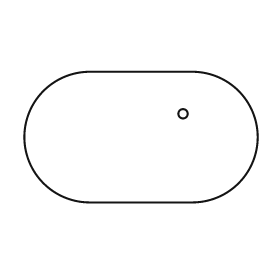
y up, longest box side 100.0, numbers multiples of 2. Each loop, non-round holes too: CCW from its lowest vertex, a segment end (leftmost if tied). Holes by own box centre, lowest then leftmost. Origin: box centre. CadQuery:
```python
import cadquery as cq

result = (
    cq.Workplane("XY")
    .moveTo(-22.0, -28.0)
    .lineTo(22.0, -28.0)
    .threePointArc((50.0, 0.0), (22.0, 28.0))
    .lineTo(-22.0, 28.0)
    .threePointArc((-50.0, 0.0), (-22.0, -28.0))
    .close()
    .moveTo(18.0, 10.0)
    .circle(2.0)
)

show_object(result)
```